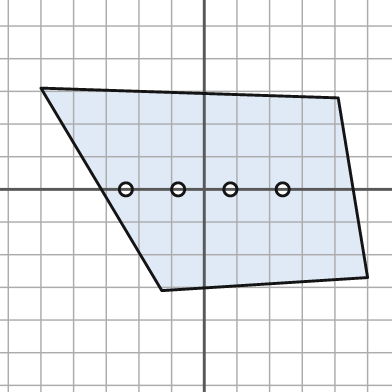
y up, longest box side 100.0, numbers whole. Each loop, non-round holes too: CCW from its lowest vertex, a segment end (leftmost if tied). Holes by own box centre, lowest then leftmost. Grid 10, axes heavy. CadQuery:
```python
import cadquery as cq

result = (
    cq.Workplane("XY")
    .moveTo(-13.0, -31.0)
    .lineTo(50.0, -27.0)
    .lineTo(41.0, 28.0)
    .lineTo(-50.0, 31.0)
    .close()
    .moveTo(-24.0, 0.0)
    .circle(2.0)
    .moveTo(-8.0, 0.0)
    .circle(2.0)
    .moveTo(8.0, 0.0)
    .circle(2.0)
    .moveTo(24.0, 0.0)
    .circle(2.0)
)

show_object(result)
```